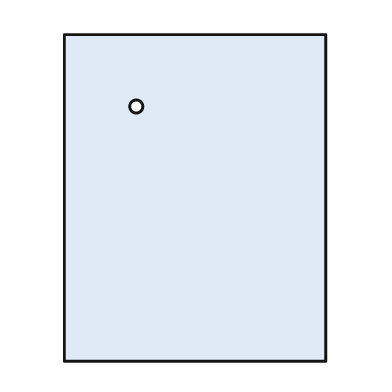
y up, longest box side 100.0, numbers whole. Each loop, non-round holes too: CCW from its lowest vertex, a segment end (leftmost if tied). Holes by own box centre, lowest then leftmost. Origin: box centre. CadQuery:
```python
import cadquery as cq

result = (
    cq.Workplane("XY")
    .moveTo(-40.0, -50.0)
    .lineTo(40.0, -50.0)
    .lineTo(40.0, 50.0)
    .lineTo(-40.0, 50.0)
    .close()
    .moveTo(-18.0, 28.0)
    .circle(2.0)
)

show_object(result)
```